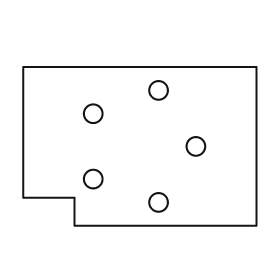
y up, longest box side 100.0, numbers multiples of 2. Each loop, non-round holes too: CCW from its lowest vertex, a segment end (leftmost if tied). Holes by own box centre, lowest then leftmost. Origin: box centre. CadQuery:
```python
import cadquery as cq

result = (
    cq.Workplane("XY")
    .moveTo(-28.0, -34.0)
    .lineTo(50.0, -34.0)
    .lineTo(50.0, 34.0)
    .lineTo(-50.0, 34.0)
    .lineTo(-50.0, -22.0)
    .lineTo(-28.0, -22.0)
    .close()
    .moveTo(8.0, -24.0)
    .circle(4.0)
    .moveTo(-20.0, -14.0)
    .circle(4.0)
    .moveTo(24.0, 0.0)
    .circle(4.0)
    .moveTo(-20.0, 14.0)
    .circle(4.0)
    .moveTo(8.0, 24.0)
    .circle(4.0)
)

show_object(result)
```